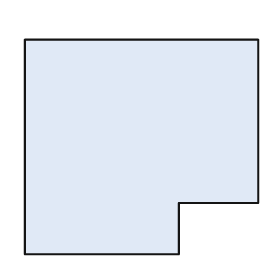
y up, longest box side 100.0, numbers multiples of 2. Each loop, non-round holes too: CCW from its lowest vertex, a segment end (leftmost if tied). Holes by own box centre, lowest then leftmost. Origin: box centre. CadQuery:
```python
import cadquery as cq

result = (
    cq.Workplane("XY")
    .moveTo(-50.0, -46.0)
    .lineTo(16.0, -46.0)
    .lineTo(16.0, -24.0)
    .lineTo(50.0, -24.0)
    .lineTo(50.0, 46.0)
    .lineTo(-50.0, 46.0)
    .close()
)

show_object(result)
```